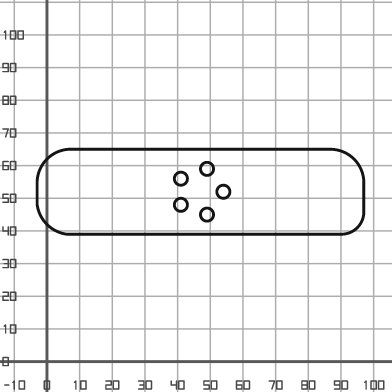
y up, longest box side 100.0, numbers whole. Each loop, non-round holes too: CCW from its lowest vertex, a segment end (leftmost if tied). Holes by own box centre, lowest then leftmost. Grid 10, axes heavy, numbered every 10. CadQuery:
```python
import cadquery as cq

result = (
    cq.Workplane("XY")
    .moveTo(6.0, 39.0)
    .lineTo(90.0, 39.0)
    .threePointArc((95.0, 41.0), (97.0, 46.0))
    .lineTo(97.0, 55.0)
    .threePointArc((94.0, 62.0), (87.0, 65.0))
    .lineTo(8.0, 65.0)
    .threePointArc((0.0, 62.0), (-3.0, 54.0))
    .lineTo(-3.0, 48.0)
    .threePointArc((0.0, 42.0), (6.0, 39.0))
    .close()
    .moveTo(49.0, 45.0)
    .circle(2.0)
    .moveTo(41.0, 48.0)
    .circle(2.0)
    .moveTo(54.0, 52.0)
    .circle(2.0)
    .moveTo(41.0, 56.0)
    .circle(2.0)
    .moveTo(49.0, 59.0)
    .circle(2.0)
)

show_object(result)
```